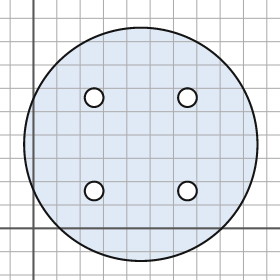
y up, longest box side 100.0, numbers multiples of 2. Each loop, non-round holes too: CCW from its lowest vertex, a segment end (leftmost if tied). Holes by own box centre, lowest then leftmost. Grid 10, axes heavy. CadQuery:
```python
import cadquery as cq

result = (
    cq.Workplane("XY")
    .moveTo(46.0, 36.0)
    .circle(50.0)
    .moveTo(26.0, 16.0)
    .circle(4.0)
    .moveTo(66.0, 16.0)
    .circle(4.0)
    .moveTo(26.0, 56.0)
    .circle(4.0)
    .moveTo(66.0, 56.0)
    .circle(4.0)
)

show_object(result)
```